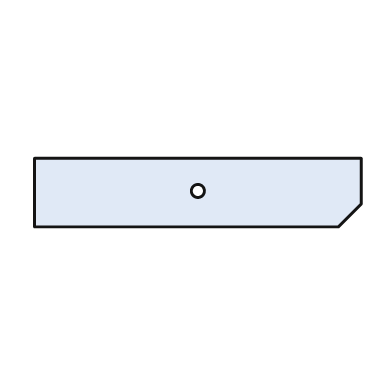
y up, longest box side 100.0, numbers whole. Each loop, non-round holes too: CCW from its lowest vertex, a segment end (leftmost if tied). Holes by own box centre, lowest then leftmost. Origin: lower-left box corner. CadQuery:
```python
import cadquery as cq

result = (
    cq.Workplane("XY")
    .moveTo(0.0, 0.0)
    .lineTo(93.0, 0.0)
    .lineTo(100.0, 7.0)
    .lineTo(100.0, 21.0)
    .lineTo(0.0, 21.0)
    .close()
    .moveTo(50.0, 11.0)
    .circle(2.0)
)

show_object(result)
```